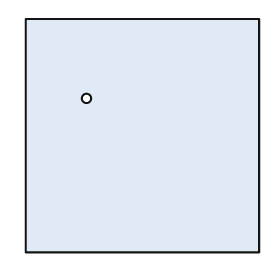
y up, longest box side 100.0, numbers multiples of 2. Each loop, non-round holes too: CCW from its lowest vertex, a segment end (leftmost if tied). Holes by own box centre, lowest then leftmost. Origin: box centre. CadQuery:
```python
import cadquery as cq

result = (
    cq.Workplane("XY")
    .moveTo(-50.0, -50.0)
    .lineTo(50.0, -50.0)
    .lineTo(50.0, 50.0)
    .lineTo(-50.0, 50.0)
    .close()
    .moveTo(-24.0, 16.0)
    .circle(2.0)
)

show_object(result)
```